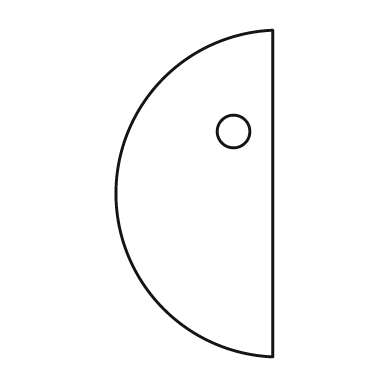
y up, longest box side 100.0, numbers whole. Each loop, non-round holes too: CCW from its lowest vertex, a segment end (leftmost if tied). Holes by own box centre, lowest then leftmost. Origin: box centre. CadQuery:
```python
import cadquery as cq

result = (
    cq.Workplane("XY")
    .moveTo(24.0, -50.0)
    .lineTo(24.0, 50.0)
    .threePointArc((-24.0, 0.0), (24.0, -50.0))
    .close()
    .moveTo(12.0, 19.0)
    .circle(5.0)
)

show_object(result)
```